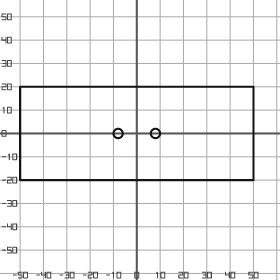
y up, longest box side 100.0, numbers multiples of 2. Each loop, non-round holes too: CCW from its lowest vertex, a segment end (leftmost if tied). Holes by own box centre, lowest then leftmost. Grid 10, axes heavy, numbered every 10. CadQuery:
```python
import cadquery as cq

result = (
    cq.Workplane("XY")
    .moveTo(-50.0, -20.0)
    .lineTo(50.0, -20.0)
    .lineTo(50.0, 20.0)
    .lineTo(-50.0, 20.0)
    .close()
    .moveTo(-8.0, 0.0)
    .circle(2.0)
    .moveTo(8.0, 0.0)
    .circle(2.0)
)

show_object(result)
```